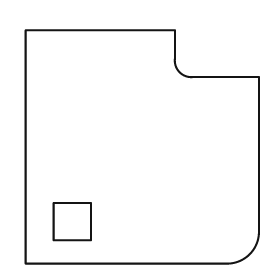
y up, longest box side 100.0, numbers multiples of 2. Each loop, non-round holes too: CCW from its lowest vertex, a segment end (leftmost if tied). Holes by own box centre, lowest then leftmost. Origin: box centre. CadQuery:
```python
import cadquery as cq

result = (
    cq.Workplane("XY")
    .moveTo(-50.0, -50.0)
    .lineTo(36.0, -50.0)
    .threePointArc((46.0, -46.0), (50.0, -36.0))
    .lineTo(50.0, 30.0)
    .lineTo(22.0, 30.0)
    .threePointArc((16.0, 32.0), (14.0, 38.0))
    .lineTo(14.0, 50.0)
    .lineTo(-50.0, 50.0)
    .close()
    .moveTo(-38.0, -40.0)
    .lineTo(-22.0, -40.0)
    .lineTo(-22.0, -24.0)
    .lineTo(-38.0, -24.0)
    .close()
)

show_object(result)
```